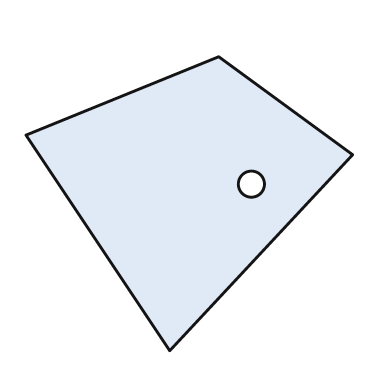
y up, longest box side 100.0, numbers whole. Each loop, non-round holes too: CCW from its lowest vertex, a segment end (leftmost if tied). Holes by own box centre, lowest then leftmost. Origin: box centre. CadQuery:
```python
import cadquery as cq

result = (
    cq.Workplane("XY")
    .moveTo(-6.0, -45.0)
    .lineTo(50.0, 15.0)
    .lineTo(9.0, 45.0)
    .lineTo(-50.0, 21.0)
    .close()
    .moveTo(19.0, 6.0)
    .circle(4.0)
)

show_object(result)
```